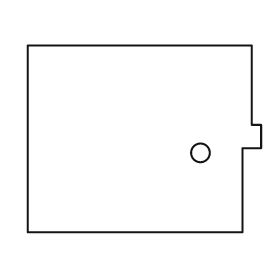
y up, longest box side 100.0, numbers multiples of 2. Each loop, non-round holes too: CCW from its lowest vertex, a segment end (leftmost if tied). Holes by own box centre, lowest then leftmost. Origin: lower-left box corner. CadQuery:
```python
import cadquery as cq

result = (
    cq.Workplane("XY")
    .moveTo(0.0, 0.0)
    .lineTo(92.0, 0.0)
    .lineTo(92.0, 36.0)
    .lineTo(100.0, 36.0)
    .lineTo(100.0, 46.0)
    .lineTo(96.0, 46.0)
    .lineTo(96.0, 80.0)
    .lineTo(0.0, 80.0)
    .close()
    .moveTo(74.0, 34.0)
    .circle(4.0)
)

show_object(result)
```